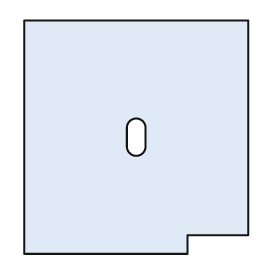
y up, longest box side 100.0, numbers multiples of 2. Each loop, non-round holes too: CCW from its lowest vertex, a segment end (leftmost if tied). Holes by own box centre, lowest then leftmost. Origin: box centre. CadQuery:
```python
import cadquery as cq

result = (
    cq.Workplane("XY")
    .moveTo(-48.0, -50.0)
    .lineTo(22.0, -50.0)
    .lineTo(22.0, -42.0)
    .lineTo(48.0, -42.0)
    .lineTo(48.0, 50.0)
    .lineTo(-48.0, 50.0)
    .close()
    .moveTo(-4.0, -4.0)
    .threePointArc((0.0, -8.0), (4.0, -4.0))
    .lineTo(4.0, 4.0)
    .threePointArc((0.0, 8.0), (-4.0, 4.0))
    .close()
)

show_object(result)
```